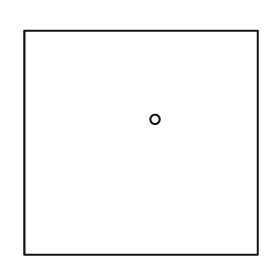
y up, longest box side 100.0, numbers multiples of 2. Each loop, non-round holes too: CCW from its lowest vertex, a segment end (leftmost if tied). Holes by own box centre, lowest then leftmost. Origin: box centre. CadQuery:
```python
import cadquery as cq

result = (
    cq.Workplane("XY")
    .moveTo(-50.0, -48.0)
    .lineTo(50.0, -48.0)
    .lineTo(50.0, 48.0)
    .lineTo(-50.0, 48.0)
    .close()
    .moveTo(6.0, 10.0)
    .circle(2.0)
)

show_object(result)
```